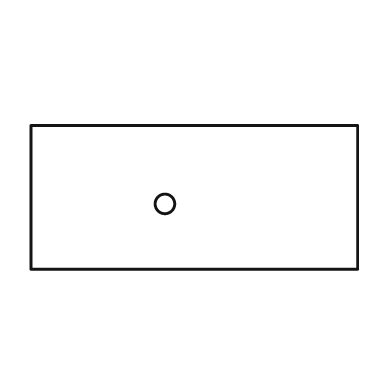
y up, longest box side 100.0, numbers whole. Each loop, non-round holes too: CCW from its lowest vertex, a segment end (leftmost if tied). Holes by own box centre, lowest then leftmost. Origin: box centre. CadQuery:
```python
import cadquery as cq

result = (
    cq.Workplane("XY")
    .moveTo(-50.0, -22.0)
    .lineTo(50.0, -22.0)
    .lineTo(50.0, 22.0)
    .lineTo(-50.0, 22.0)
    .close()
    .moveTo(-9.0, -2.0)
    .circle(3.0)
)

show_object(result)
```